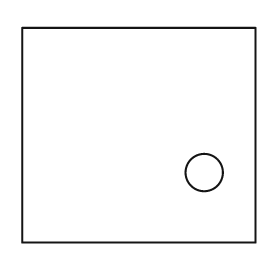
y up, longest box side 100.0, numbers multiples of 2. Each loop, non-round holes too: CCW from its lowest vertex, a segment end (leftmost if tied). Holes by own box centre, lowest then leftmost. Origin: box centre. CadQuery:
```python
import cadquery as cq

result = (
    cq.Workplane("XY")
    .moveTo(-50.0, -46.0)
    .lineTo(50.0, -46.0)
    .lineTo(50.0, 46.0)
    .lineTo(-50.0, 46.0)
    .close()
    .moveTo(28.0, -16.0)
    .circle(8.0)
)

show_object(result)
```